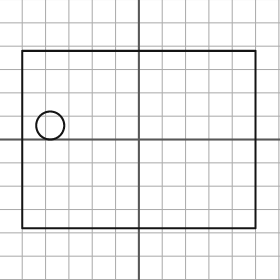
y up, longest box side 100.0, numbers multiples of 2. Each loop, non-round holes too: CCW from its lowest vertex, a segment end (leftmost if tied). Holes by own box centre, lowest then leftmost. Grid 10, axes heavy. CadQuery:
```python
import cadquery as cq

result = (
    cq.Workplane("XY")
    .moveTo(-50.0, -38.0)
    .lineTo(50.0, -38.0)
    .lineTo(50.0, 38.0)
    .lineTo(-50.0, 38.0)
    .close()
    .moveTo(-38.0, 6.0)
    .circle(6.0)
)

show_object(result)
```